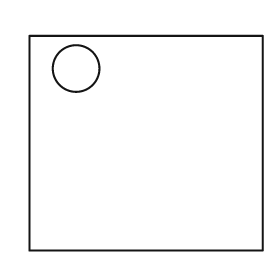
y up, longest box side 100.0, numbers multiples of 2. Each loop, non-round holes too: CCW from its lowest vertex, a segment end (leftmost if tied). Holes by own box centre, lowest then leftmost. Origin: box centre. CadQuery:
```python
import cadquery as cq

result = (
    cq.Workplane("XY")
    .moveTo(-50.0, -46.0)
    .lineTo(50.0, -46.0)
    .lineTo(50.0, 46.0)
    .lineTo(-50.0, 46.0)
    .close()
    .moveTo(-30.0, 32.0)
    .circle(10.0)
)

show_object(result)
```